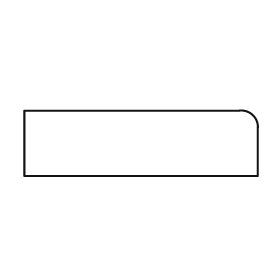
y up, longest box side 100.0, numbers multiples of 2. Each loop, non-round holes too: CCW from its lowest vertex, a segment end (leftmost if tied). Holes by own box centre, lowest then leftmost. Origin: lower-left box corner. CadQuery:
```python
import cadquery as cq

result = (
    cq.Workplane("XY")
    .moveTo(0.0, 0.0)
    .lineTo(100.0, 0.0)
    .lineTo(100.0, 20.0)
    .threePointArc((98.0, 26.0), (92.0, 28.0))
    .lineTo(0.0, 28.0)
    .close()
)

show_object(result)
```